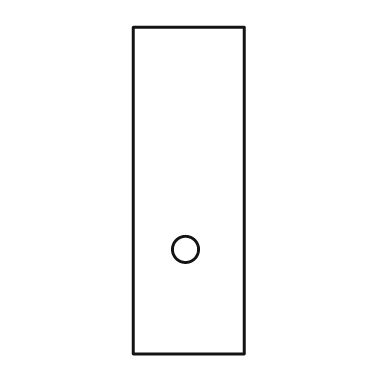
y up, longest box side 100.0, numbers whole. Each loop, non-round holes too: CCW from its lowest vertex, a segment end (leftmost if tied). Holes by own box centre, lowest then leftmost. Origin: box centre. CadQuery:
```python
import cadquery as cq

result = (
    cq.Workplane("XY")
    .moveTo(-17.0, -50.0)
    .lineTo(17.0, -50.0)
    .lineTo(17.0, 50.0)
    .lineTo(-17.0, 50.0)
    .close()
    .moveTo(-1.0, -18.0)
    .circle(4.0)
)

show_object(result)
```